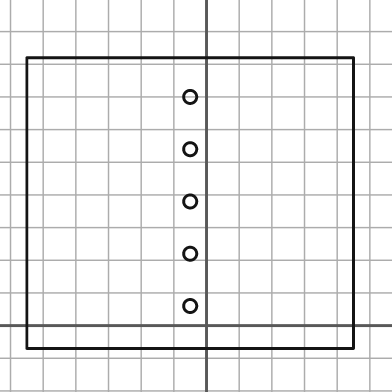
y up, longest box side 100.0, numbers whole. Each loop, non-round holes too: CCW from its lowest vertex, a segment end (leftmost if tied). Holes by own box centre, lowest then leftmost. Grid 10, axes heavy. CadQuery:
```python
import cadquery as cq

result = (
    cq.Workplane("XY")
    .moveTo(-55.0, -7.0)
    .lineTo(45.0, -7.0)
    .lineTo(45.0, 82.0)
    .lineTo(-55.0, 82.0)
    .close()
    .moveTo(-5.0, 6.0)
    .circle(2.0)
    .moveTo(-5.0, 22.0)
    .circle(2.0)
    .moveTo(-5.0, 38.0)
    .circle(2.0)
    .moveTo(-5.0, 54.0)
    .circle(2.0)
    .moveTo(-5.0, 70.0)
    .circle(2.0)
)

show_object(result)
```